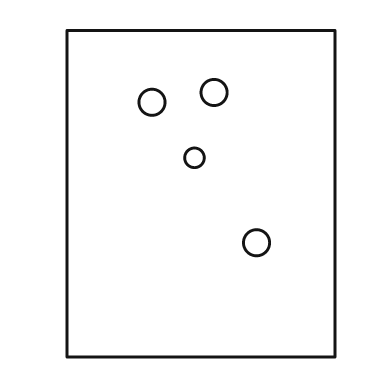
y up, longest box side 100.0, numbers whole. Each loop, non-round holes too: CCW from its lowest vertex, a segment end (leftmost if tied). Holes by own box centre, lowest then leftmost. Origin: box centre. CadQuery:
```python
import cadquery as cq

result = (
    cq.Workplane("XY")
    .moveTo(-41.0, -50.0)
    .lineTo(41.0, -50.0)
    .lineTo(41.0, 50.0)
    .lineTo(-41.0, 50.0)
    .close()
    .moveTo(17.0, -15.0)
    .circle(4.0)
    .moveTo(-2.0, 11.0)
    .circle(3.0)
    .moveTo(-15.0, 28.0)
    .circle(4.0)
    .moveTo(4.0, 31.0)
    .circle(4.0)
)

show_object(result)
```